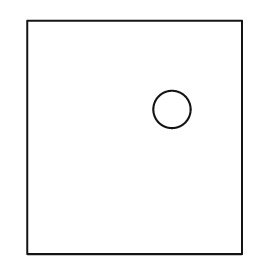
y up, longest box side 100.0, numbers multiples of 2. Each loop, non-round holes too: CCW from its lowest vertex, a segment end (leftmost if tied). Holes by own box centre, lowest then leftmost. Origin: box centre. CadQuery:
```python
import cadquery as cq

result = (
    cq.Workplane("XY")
    .moveTo(-46.0, -50.0)
    .lineTo(46.0, -50.0)
    .lineTo(46.0, 50.0)
    .lineTo(-46.0, 50.0)
    .close()
    .moveTo(16.0, 12.0)
    .circle(8.0)
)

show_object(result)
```